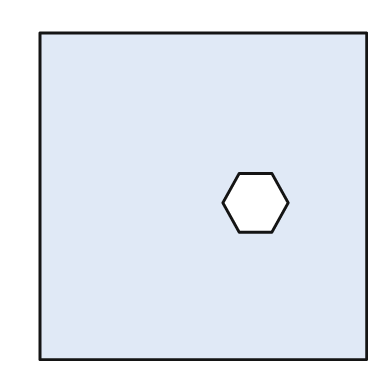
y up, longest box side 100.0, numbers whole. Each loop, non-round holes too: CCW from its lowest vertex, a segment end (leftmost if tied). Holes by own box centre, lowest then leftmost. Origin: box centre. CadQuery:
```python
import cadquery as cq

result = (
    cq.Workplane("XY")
    .moveTo(-50.0, -50.0)
    .lineTo(50.0, -50.0)
    .lineTo(50.0, 50.0)
    .lineTo(-50.0, 50.0)
    .close()
    .moveTo(11.0, -11.0)
    .lineTo(21.0, -11.0)
    .lineTo(26.0, -2.0)
    .lineTo(21.0, 7.0)
    .lineTo(11.0, 7.0)
    .lineTo(6.0, -2.0)
    .close()
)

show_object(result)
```